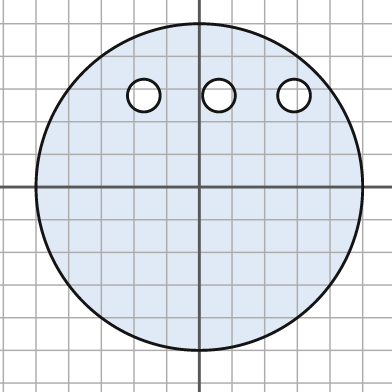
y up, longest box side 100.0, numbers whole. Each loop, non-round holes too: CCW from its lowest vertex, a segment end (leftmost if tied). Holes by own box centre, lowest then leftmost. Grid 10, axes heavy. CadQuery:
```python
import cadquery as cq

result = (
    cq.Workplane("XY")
    .moveTo(0.0, 0.0)
    .circle(50.0)
    .moveTo(-17.0, 28.0)
    .circle(5.0)
    .moveTo(6.0, 28.0)
    .circle(5.0)
    .moveTo(29.0, 28.0)
    .circle(5.0)
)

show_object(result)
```